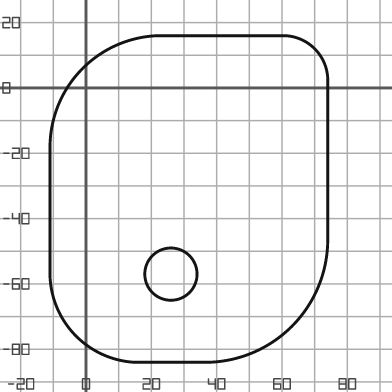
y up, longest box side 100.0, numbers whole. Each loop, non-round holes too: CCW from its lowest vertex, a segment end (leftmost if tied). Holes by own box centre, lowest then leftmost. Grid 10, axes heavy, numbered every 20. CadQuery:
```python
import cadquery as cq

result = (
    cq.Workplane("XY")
    .moveTo(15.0, -84.0)
    .lineTo(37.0, -84.0)
    .threePointArc((63.0, -73.0), (74.0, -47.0))
    .lineTo(74.0, 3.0)
    .threePointArc((70.0, 12.0), (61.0, 16.0))
    .lineTo(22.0, 16.0)
    .threePointArc((-1.0, 6.0), (-11.0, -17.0))
    .lineTo(-11.0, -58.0)
    .threePointArc((-3.0, -76.0), (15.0, -84.0))
    .close()
    .moveTo(26.0, -57.0)
    .circle(8.0)
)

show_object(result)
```